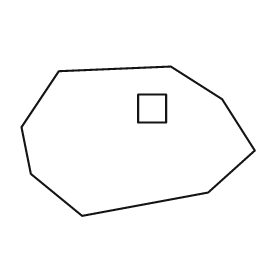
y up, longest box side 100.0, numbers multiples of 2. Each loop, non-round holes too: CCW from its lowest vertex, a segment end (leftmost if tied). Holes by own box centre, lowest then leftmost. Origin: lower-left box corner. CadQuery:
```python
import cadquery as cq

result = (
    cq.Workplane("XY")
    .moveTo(26.0, 0.0)
    .lineTo(80.0, 10.0)
    .lineTo(100.0, 28.0)
    .lineTo(86.0, 50.0)
    .lineTo(64.0, 64.0)
    .lineTo(16.0, 62.0)
    .lineTo(0.0, 38.0)
    .lineTo(4.0, 18.0)
    .close()
    .moveTo(50.0, 40.0)
    .lineTo(62.0, 40.0)
    .lineTo(62.0, 52.0)
    .lineTo(50.0, 52.0)
    .close()
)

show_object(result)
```